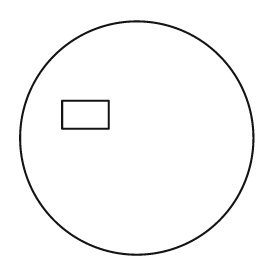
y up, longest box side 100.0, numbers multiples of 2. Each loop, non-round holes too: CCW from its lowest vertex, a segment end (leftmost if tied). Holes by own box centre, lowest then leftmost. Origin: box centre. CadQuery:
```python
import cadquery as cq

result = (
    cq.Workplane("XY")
    .moveTo(0.0, 0.0)
    .circle(50.0)
    .moveTo(-32.0, 4.0)
    .lineTo(-12.0, 4.0)
    .lineTo(-12.0, 16.0)
    .lineTo(-32.0, 16.0)
    .close()
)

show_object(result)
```